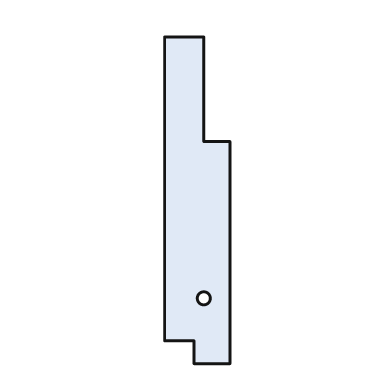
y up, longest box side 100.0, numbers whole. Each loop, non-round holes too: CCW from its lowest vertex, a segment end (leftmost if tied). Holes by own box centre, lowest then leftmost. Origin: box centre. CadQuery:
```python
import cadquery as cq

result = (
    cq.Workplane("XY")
    .moveTo(-1.0, -50.0)
    .lineTo(10.0, -50.0)
    .lineTo(10.0, 18.0)
    .lineTo(2.0, 18.0)
    .lineTo(2.0, 50.0)
    .lineTo(-10.0, 50.0)
    .lineTo(-10.0, -43.0)
    .lineTo(-1.0, -43.0)
    .close()
    .moveTo(2.0, -30.0)
    .circle(2.0)
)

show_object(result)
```